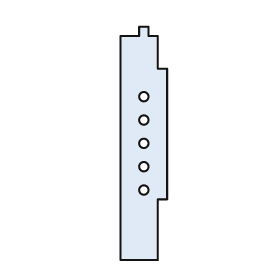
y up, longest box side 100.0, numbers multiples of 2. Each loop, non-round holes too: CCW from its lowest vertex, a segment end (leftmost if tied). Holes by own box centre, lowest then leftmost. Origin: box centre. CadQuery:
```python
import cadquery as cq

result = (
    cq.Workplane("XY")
    .moveTo(-10.0, -50.0)
    .lineTo(6.0, -50.0)
    .lineTo(6.0, -24.0)
    .lineTo(10.0, -24.0)
    .lineTo(10.0, 32.0)
    .lineTo(6.0, 32.0)
    .lineTo(6.0, 46.0)
    .lineTo(2.0, 46.0)
    .lineTo(2.0, 50.0)
    .lineTo(-2.0, 50.0)
    .lineTo(-2.0, 46.0)
    .lineTo(-10.0, 46.0)
    .close()
    .moveTo(0.0, -20.0)
    .circle(2.0)
    .moveTo(0.0, -10.0)
    .circle(2.0)
    .moveTo(0.0, 0.0)
    .circle(2.0)
    .moveTo(0.0, 10.0)
    .circle(2.0)
    .moveTo(0.0, 20.0)
    .circle(2.0)
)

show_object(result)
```